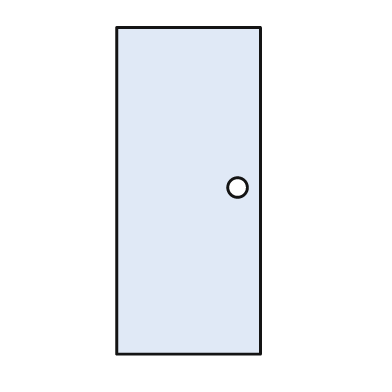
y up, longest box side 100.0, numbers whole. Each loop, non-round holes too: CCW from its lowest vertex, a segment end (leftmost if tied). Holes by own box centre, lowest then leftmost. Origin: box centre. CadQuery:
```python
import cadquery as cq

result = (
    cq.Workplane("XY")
    .moveTo(-22.0, -50.0)
    .lineTo(22.0, -50.0)
    .lineTo(22.0, 50.0)
    .lineTo(-22.0, 50.0)
    .close()
    .moveTo(15.0, 1.0)
    .circle(3.0)
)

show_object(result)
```